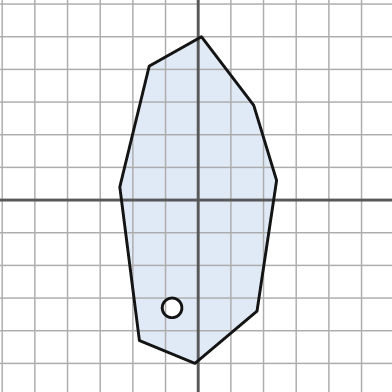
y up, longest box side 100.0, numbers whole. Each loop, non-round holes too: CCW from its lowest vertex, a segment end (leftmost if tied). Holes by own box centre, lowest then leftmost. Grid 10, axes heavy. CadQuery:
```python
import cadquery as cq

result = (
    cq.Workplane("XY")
    .moveTo(-1.0, -50.0)
    .lineTo(18.0, -34.0)
    .lineTo(24.0, 6.0)
    .lineTo(17.0, 29.0)
    .lineTo(1.0, 50.0)
    .lineTo(-15.0, 41.0)
    .lineTo(-24.0, 4.0)
    .lineTo(-18.0, -43.0)
    .close()
    .moveTo(-8.0, -33.0)
    .circle(3.0)
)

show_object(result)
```